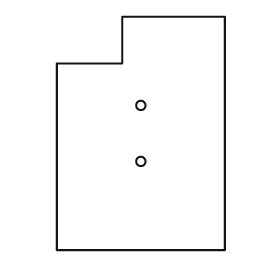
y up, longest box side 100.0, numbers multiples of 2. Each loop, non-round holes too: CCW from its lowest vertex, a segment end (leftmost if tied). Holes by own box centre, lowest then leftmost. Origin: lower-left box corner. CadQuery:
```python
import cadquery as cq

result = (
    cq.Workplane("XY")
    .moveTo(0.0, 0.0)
    .lineTo(72.0, 0.0)
    .lineTo(72.0, 100.0)
    .lineTo(28.0, 100.0)
    .lineTo(28.0, 80.0)
    .lineTo(0.0, 80.0)
    .close()
    .moveTo(36.0, 38.0)
    .circle(2.0)
    .moveTo(36.0, 62.0)
    .circle(2.0)
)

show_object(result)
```